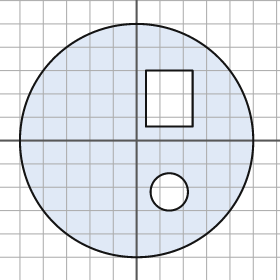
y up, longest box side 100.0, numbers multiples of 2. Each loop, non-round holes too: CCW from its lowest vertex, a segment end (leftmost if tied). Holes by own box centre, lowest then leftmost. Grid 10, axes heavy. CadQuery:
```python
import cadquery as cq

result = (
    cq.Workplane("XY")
    .moveTo(0.0, 0.0)
    .circle(50.0)
    .moveTo(14.0, -22.0)
    .circle(8.0)
    .moveTo(4.0, 6.0)
    .lineTo(24.0, 6.0)
    .lineTo(24.0, 30.0)
    .lineTo(4.0, 30.0)
    .close()
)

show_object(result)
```